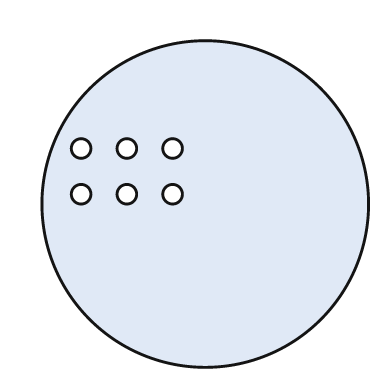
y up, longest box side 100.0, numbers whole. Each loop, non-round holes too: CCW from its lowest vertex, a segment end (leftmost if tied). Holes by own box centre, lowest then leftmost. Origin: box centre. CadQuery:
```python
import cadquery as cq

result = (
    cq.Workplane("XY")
    .moveTo(0.0, 0.0)
    .circle(50.0)
    .moveTo(-38.0, 3.0)
    .circle(3.0)
    .moveTo(-24.0, 3.0)
    .circle(3.0)
    .moveTo(-10.0, 3.0)
    .circle(3.0)
    .moveTo(-38.0, 17.0)
    .circle(3.0)
    .moveTo(-24.0, 17.0)
    .circle(3.0)
    .moveTo(-10.0, 17.0)
    .circle(3.0)
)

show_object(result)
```